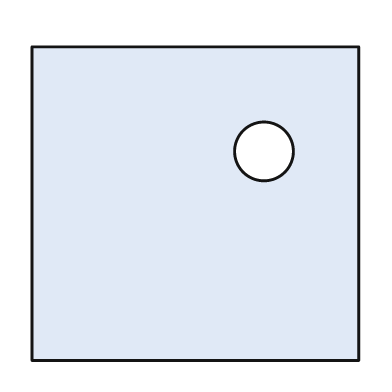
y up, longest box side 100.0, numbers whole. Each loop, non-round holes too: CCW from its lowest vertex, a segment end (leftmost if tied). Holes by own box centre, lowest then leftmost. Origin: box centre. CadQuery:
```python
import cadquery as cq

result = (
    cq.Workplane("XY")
    .moveTo(-50.0, -48.0)
    .lineTo(50.0, -48.0)
    .lineTo(50.0, 48.0)
    .lineTo(-50.0, 48.0)
    .close()
    .moveTo(21.0, 16.0)
    .circle(9.0)
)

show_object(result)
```